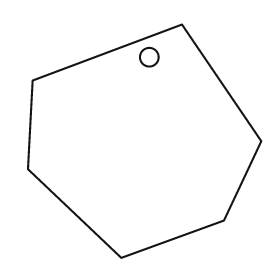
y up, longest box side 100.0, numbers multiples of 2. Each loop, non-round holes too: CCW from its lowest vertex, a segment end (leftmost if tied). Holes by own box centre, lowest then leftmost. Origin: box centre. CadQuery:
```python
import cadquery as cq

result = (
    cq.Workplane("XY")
    .moveTo(-10.0, -50.0)
    .lineTo(34.0, -34.0)
    .lineTo(50.0, 0.0)
    .lineTo(16.0, 50.0)
    .lineTo(-48.0, 26.0)
    .lineTo(-50.0, -12.0)
    .close()
    .moveTo(2.0, 36.0)
    .circle(4.0)
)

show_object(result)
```